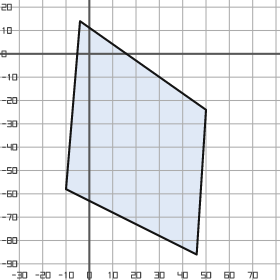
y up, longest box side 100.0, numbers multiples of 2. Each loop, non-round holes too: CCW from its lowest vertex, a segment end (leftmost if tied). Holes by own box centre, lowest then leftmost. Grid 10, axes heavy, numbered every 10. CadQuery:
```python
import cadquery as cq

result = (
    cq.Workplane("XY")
    .moveTo(46.0, -86.0)
    .lineTo(50.0, -24.0)
    .lineTo(-4.0, 14.0)
    .lineTo(-10.0, -58.0)
    .close()
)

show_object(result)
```